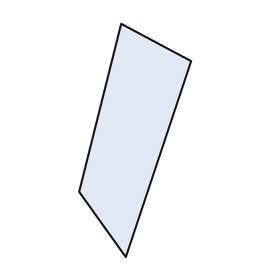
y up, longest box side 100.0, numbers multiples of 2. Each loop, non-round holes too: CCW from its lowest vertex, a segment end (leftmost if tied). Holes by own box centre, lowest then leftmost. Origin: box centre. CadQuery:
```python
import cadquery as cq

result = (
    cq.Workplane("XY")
    .moveTo(-4.0, -50.0)
    .lineTo(24.0, 34.0)
    .lineTo(-6.0, 50.0)
    .lineTo(-24.0, -22.0)
    .close()
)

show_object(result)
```